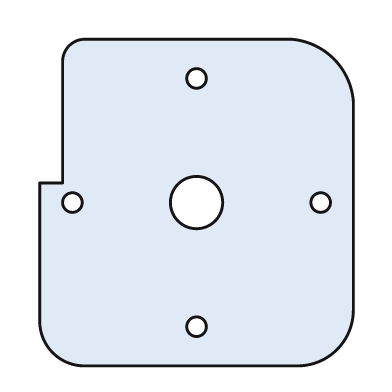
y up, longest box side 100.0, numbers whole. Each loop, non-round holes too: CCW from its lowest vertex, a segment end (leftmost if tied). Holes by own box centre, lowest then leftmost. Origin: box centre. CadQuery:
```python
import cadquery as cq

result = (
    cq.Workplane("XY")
    .moveTo(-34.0, -50.0)
    .lineTo(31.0, -50.0)
    .threePointArc((43.0, -45.0), (48.0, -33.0))
    .lineTo(48.0, 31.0)
    .threePointArc((42.0, 44.0), (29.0, 50.0))
    .lineTo(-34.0, 50.0)
    .threePointArc((-39.0, 48.0), (-41.0, 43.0))
    .lineTo(-41.0, 6.0)
    .lineTo(-48.0, 6.0)
    .lineTo(-48.0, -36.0)
    .threePointArc((-44.0, -46.0), (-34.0, -50.0))
    .close()
    .moveTo(0.0, -38.0)
    .circle(3.0)
    .moveTo(-38.0, 0.0)
    .circle(3.0)
    .moveTo(0.0, 0.0)
    .circle(8.0)
    .moveTo(38.0, 0.0)
    .circle(3.0)
    .moveTo(0.0, 38.0)
    .circle(3.0)
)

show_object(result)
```